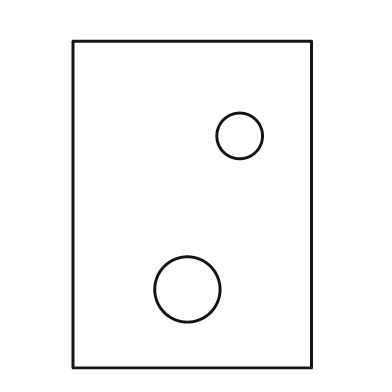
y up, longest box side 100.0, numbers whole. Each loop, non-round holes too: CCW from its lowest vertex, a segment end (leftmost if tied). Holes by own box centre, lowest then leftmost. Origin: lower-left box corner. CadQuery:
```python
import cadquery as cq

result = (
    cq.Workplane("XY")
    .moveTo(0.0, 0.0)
    .lineTo(73.0, 0.0)
    .lineTo(73.0, 100.0)
    .lineTo(0.0, 100.0)
    .close()
    .moveTo(35.0, 24.0)
    .circle(10.0)
    .moveTo(51.0, 71.0)
    .circle(7.0)
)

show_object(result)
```